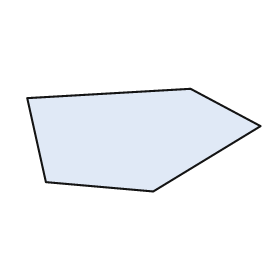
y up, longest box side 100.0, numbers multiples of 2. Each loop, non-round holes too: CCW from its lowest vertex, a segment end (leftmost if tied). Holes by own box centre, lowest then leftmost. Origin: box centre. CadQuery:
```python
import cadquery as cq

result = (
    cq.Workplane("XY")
    .moveTo(4.0, -22.0)
    .lineTo(50.0, 6.0)
    .lineTo(20.0, 22.0)
    .lineTo(-50.0, 18.0)
    .lineTo(-42.0, -18.0)
    .close()
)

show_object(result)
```